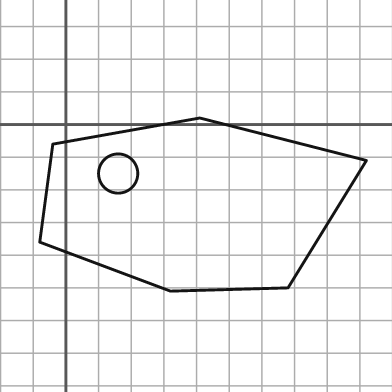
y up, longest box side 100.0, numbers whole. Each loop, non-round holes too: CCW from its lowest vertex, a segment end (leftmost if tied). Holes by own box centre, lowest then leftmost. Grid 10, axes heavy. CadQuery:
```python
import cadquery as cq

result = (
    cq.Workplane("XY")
    .moveTo(32.0, -51.0)
    .lineTo(68.0, -50.0)
    .lineTo(92.0, -11.0)
    .lineTo(41.0, 2.0)
    .lineTo(-4.0, -6.0)
    .lineTo(-8.0, -36.0)
    .close()
    .moveTo(16.0, -15.0)
    .circle(6.0)
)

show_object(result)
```